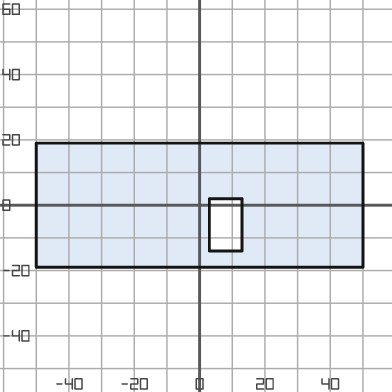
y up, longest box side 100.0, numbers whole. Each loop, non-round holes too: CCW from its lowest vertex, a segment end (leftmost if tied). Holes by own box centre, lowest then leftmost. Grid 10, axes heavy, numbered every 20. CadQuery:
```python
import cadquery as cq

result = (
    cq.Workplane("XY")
    .moveTo(-50.0, -19.0)
    .lineTo(50.0, -19.0)
    .lineTo(50.0, 19.0)
    .lineTo(-50.0, 19.0)
    .close()
    .moveTo(3.0, -14.0)
    .lineTo(13.0, -14.0)
    .lineTo(13.0, 2.0)
    .lineTo(3.0, 2.0)
    .close()
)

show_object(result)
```